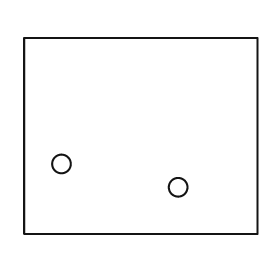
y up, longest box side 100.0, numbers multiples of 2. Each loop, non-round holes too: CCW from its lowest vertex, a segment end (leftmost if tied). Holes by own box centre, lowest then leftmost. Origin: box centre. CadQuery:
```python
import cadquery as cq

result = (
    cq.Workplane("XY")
    .moveTo(-50.0, -42.0)
    .lineTo(50.0, -42.0)
    .lineTo(50.0, 42.0)
    .lineTo(-50.0, 42.0)
    .close()
    .moveTo(16.0, -22.0)
    .circle(4.0)
    .moveTo(-34.0, -12.0)
    .circle(4.0)
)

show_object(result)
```